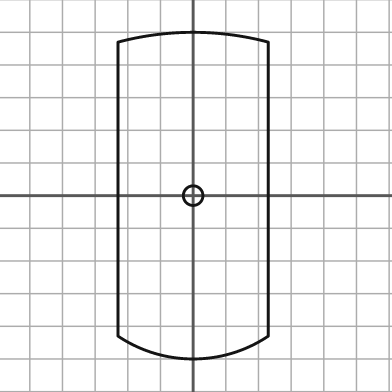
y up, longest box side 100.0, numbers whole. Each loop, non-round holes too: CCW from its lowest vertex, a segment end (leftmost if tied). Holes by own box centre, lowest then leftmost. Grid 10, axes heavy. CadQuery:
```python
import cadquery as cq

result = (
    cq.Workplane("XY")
    .moveTo(-23.0, -43.0)
    .threePointArc((0.0, -50.0), (23.0, -43.0))
    .lineTo(23.0, 47.0)
    .threePointArc((0.0, 50.0), (-23.0, 47.0))
    .close()
    .moveTo(0.0, 0.0)
    .circle(3.0)
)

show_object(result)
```